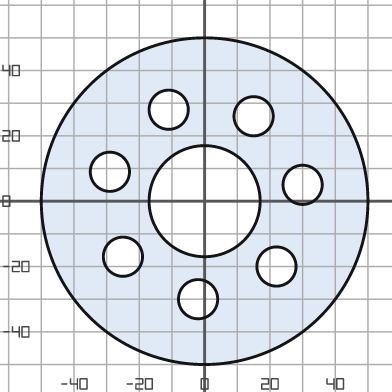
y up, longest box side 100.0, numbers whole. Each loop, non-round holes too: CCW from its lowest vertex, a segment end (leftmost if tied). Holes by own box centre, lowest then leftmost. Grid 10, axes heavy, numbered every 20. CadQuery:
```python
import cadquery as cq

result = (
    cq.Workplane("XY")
    .moveTo(0.0, 0.0)
    .circle(50.0)
    .moveTo(-2.0, -30.0)
    .circle(6.0)
    .moveTo(22.0, -20.0)
    .circle(6.0)
    .moveTo(-25.0, -17.0)
    .circle(6.0)
    .moveTo(0.0, 0.0)
    .circle(17.0)
    .moveTo(30.0, 5.0)
    .circle(6.0)
    .moveTo(-29.0, 9.0)
    .circle(6.0)
    .moveTo(15.0, 26.0)
    .circle(6.0)
    .moveTo(-11.0, 28.0)
    .circle(6.0)
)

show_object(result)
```